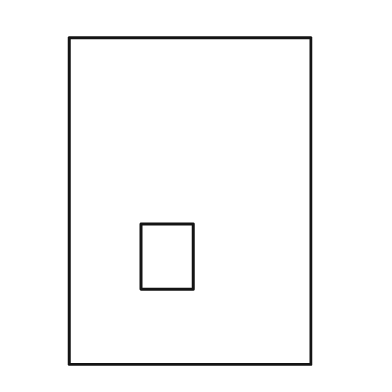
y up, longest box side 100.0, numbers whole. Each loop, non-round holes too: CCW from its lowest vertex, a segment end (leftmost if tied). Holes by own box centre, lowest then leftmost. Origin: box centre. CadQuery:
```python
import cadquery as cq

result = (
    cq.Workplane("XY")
    .moveTo(-37.0, -50.0)
    .lineTo(37.0, -50.0)
    .lineTo(37.0, 50.0)
    .lineTo(-37.0, 50.0)
    .close()
    .moveTo(-15.0, -27.0)
    .lineTo(1.0, -27.0)
    .lineTo(1.0, -7.0)
    .lineTo(-15.0, -7.0)
    .close()
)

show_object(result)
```